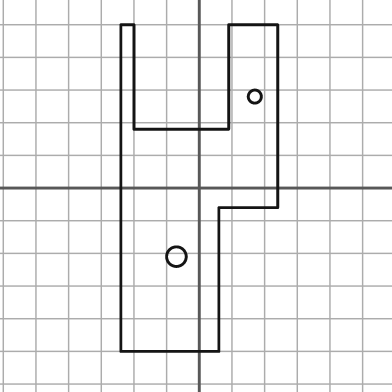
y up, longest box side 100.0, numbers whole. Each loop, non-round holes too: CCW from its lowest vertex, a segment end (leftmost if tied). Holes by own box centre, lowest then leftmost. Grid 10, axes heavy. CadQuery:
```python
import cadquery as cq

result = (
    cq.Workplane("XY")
    .moveTo(-24.0, -50.0)
    .lineTo(6.0, -50.0)
    .lineTo(6.0, -6.0)
    .lineTo(24.0, -6.0)
    .lineTo(24.0, 50.0)
    .lineTo(9.0, 50.0)
    .lineTo(9.0, 18.0)
    .lineTo(-20.0, 18.0)
    .lineTo(-20.0, 50.0)
    .lineTo(-24.0, 50.0)
    .close()
    .moveTo(-7.0, -21.0)
    .circle(3.0)
    .moveTo(17.0, 28.0)
    .circle(2.0)
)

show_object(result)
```